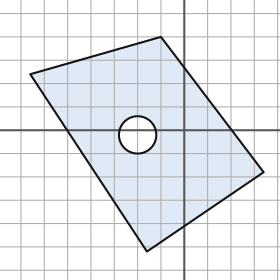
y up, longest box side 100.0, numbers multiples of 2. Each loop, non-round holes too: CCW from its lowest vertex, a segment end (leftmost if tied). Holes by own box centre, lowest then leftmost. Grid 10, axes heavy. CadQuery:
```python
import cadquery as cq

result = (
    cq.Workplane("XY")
    .moveTo(-16.0, -52.0)
    .lineTo(34.0, -18.0)
    .lineTo(-10.0, 40.0)
    .lineTo(-66.0, 24.0)
    .close()
    .moveTo(-20.0, -2.0)
    .circle(8.0)
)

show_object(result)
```